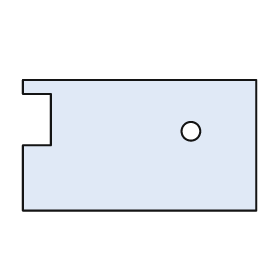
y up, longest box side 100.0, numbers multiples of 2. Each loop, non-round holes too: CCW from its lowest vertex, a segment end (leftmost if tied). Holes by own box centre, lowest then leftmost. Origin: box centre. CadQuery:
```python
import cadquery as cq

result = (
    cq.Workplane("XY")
    .moveTo(-50.0, -28.0)
    .lineTo(50.0, -28.0)
    .lineTo(50.0, 28.0)
    .lineTo(-50.0, 28.0)
    .lineTo(-50.0, 22.0)
    .lineTo(-38.0, 22.0)
    .lineTo(-38.0, 0.0)
    .lineTo(-50.0, 0.0)
    .close()
    .moveTo(22.0, 6.0)
    .circle(4.0)
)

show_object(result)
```